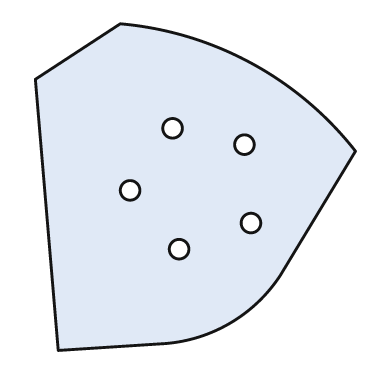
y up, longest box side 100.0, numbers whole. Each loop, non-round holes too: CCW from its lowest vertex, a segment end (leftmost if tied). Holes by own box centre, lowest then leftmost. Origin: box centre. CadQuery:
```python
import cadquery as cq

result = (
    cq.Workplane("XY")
    .moveTo(-42.0, -50.0)
    .lineTo(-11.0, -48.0)
    .threePointArc((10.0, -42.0), (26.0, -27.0))
    .lineTo(49.0, 11.0)
    .threePointArc((17.0, 38.0), (-23.0, 50.0))
    .lineTo(-49.0, 33.0)
    .close()
    .moveTo(-5.0, -19.0)
    .circle(3.0)
    .moveTo(17.0, -11.0)
    .circle(3.0)
    .moveTo(-20.0, -1.0)
    .circle(3.0)
    .moveTo(15.0, 13.0)
    .circle(3.0)
    .moveTo(-7.0, 18.0)
    .circle(3.0)
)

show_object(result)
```